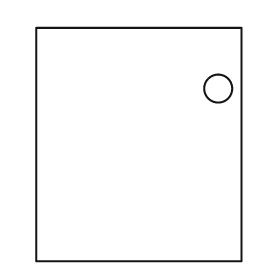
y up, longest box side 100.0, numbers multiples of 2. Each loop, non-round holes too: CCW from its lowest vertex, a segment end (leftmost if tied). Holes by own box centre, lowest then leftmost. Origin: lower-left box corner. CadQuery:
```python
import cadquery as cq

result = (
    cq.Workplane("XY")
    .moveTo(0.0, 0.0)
    .lineTo(88.0, 0.0)
    .lineTo(88.0, 100.0)
    .lineTo(0.0, 100.0)
    .close()
    .moveTo(78.0, 74.0)
    .circle(6.0)
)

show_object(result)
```